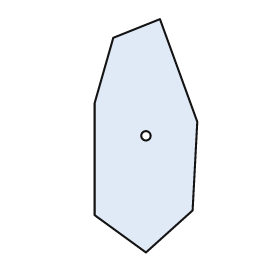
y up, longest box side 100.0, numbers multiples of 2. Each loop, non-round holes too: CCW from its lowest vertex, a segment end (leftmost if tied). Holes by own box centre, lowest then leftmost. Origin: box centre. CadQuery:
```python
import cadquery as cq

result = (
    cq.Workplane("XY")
    .moveTo(0.0, -50.0)
    .lineTo(20.0, -32.0)
    .lineTo(22.0, 6.0)
    .lineTo(6.0, 50.0)
    .lineTo(-14.0, 42.0)
    .lineTo(-22.0, 14.0)
    .lineTo(-22.0, -34.0)
    .close()
    .moveTo(0.0, 0.0)
    .circle(2.0)
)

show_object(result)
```